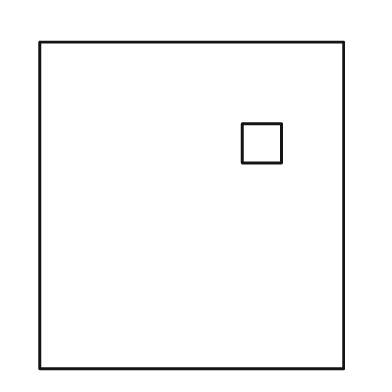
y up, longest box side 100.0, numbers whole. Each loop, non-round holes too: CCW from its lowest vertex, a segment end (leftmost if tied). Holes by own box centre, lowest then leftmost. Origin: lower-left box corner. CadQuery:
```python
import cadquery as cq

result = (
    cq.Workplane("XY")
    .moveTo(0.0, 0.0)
    .lineTo(93.0, 0.0)
    .lineTo(93.0, 100.0)
    .lineTo(0.0, 100.0)
    .close()
    .moveTo(62.0, 63.0)
    .lineTo(74.0, 63.0)
    .lineTo(74.0, 75.0)
    .lineTo(62.0, 75.0)
    .close()
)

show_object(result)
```